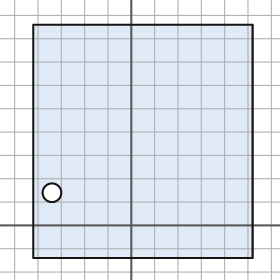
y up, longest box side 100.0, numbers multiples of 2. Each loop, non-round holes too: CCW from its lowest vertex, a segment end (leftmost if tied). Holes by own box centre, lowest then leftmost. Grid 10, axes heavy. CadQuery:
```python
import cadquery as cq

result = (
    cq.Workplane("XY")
    .moveTo(-42.0, -14.0)
    .lineTo(52.0, -14.0)
    .lineTo(52.0, 86.0)
    .lineTo(-42.0, 86.0)
    .close()
    .moveTo(-34.0, 14.0)
    .circle(4.0)
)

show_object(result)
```